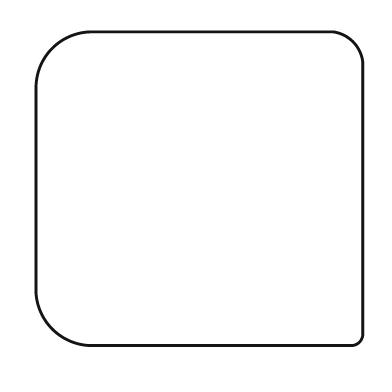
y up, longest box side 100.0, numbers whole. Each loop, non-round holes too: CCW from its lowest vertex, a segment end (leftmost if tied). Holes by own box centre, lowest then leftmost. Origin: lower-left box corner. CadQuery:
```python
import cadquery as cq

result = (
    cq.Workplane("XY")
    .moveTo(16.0, 0.0)
    .lineTo(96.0, 0.0)
    .threePointArc((99.0, 1.0), (100.0, 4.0))
    .lineTo(100.0, 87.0)
    .threePointArc((97.0, 93.0), (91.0, 96.0))
    .lineTo(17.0, 96.0)
    .threePointArc((5.0, 91.0), (0.0, 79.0))
    .lineTo(0.0, 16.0)
    .threePointArc((5.0, 5.0), (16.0, 0.0))
    .close()
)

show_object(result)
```